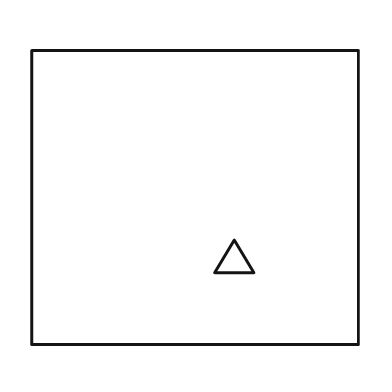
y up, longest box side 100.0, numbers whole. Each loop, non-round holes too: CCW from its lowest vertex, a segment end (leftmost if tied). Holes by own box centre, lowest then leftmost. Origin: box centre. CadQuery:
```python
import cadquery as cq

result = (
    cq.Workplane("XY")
    .moveTo(-50.0, -45.0)
    .lineTo(50.0, -45.0)
    .lineTo(50.0, 45.0)
    .lineTo(-50.0, 45.0)
    .close()
    .moveTo(6.0, -23.0)
    .lineTo(18.0, -23.0)
    .lineTo(12.0, -13.0)
    .close()
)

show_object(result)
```